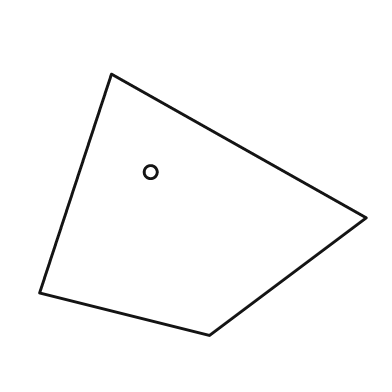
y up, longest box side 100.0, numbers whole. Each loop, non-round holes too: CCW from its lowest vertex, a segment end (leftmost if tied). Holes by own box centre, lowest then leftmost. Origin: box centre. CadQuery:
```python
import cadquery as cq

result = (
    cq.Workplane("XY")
    .moveTo(2.0, -40.0)
    .lineTo(50.0, -4.0)
    .lineTo(-28.0, 40.0)
    .lineTo(-50.0, -27.0)
    .close()
    .moveTo(-16.0, 10.0)
    .circle(2.0)
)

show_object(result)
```